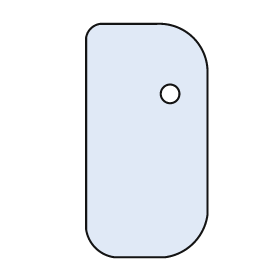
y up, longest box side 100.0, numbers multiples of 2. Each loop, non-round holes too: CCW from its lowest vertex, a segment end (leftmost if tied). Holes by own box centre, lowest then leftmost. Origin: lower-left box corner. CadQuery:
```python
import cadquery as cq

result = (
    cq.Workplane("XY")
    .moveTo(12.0, 0.0)
    .lineTo(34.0, 0.0)
    .threePointArc((46.0, 6.0), (52.0, 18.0))
    .lineTo(52.0, 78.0)
    .threePointArc((46.0, 94.0), (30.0, 100.0))
    .lineTo(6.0, 100.0)
    .threePointArc((2.0, 98.0), (0.0, 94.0))
    .lineTo(0.0, 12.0)
    .threePointArc((4.0, 4.0), (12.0, 0.0))
    .close()
    .moveTo(36.0, 70.0)
    .circle(4.0)
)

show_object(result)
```